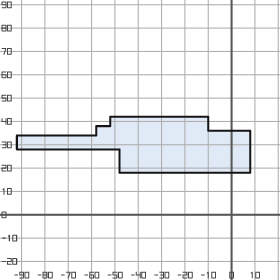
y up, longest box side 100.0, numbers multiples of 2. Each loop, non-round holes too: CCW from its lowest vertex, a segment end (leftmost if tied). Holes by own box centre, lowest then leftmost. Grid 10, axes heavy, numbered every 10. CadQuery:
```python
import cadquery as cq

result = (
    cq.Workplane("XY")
    .moveTo(-48.0, 18.0)
    .lineTo(8.0, 18.0)
    .lineTo(8.0, 36.0)
    .lineTo(-10.0, 36.0)
    .lineTo(-10.0, 42.0)
    .lineTo(-52.0, 42.0)
    .lineTo(-52.0, 38.0)
    .lineTo(-58.0, 38.0)
    .lineTo(-58.0, 34.0)
    .lineTo(-92.0, 34.0)
    .lineTo(-92.0, 28.0)
    .lineTo(-48.0, 28.0)
    .close()
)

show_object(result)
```